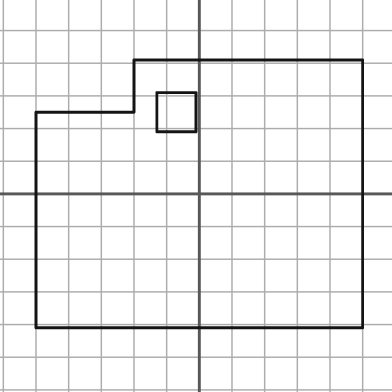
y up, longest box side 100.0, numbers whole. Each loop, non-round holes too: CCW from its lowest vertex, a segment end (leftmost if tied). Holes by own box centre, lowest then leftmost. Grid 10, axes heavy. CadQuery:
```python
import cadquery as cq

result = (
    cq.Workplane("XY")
    .moveTo(-50.0, -41.0)
    .lineTo(50.0, -41.0)
    .lineTo(50.0, 41.0)
    .lineTo(-20.0, 41.0)
    .lineTo(-20.0, 25.0)
    .lineTo(-50.0, 25.0)
    .close()
    .moveTo(-13.0, 19.0)
    .lineTo(-1.0, 19.0)
    .lineTo(-1.0, 31.0)
    .lineTo(-13.0, 31.0)
    .close()
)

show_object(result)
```